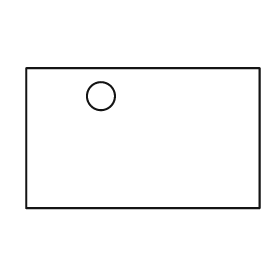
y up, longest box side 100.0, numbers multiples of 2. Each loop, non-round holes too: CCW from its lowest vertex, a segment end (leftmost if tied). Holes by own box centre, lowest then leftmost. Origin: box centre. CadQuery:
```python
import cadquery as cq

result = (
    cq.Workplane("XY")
    .moveTo(-50.0, -30.0)
    .lineTo(50.0, -30.0)
    .lineTo(50.0, 30.0)
    .lineTo(-50.0, 30.0)
    .close()
    .moveTo(-18.0, 18.0)
    .circle(6.0)
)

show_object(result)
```